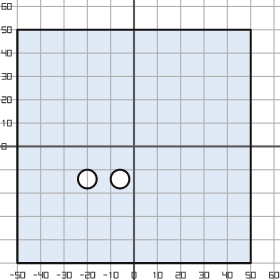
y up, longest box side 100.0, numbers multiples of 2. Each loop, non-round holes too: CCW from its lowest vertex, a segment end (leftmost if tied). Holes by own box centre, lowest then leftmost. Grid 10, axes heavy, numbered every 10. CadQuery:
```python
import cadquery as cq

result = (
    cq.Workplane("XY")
    .moveTo(-50.0, -50.0)
    .lineTo(50.0, -50.0)
    .lineTo(50.0, 50.0)
    .lineTo(-50.0, 50.0)
    .close()
    .moveTo(-20.0, -14.0)
    .circle(4.0)
    .moveTo(-6.0, -14.0)
    .circle(4.0)
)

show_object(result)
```